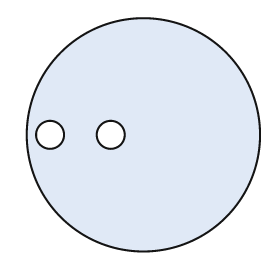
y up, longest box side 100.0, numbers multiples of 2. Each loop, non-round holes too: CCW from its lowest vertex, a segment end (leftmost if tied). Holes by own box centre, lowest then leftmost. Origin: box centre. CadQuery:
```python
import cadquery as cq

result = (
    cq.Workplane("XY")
    .moveTo(0.0, 0.0)
    .circle(50.0)
    .moveTo(-40.0, 0.0)
    .circle(6.0)
    .moveTo(-14.0, 0.0)
    .circle(6.0)
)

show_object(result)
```